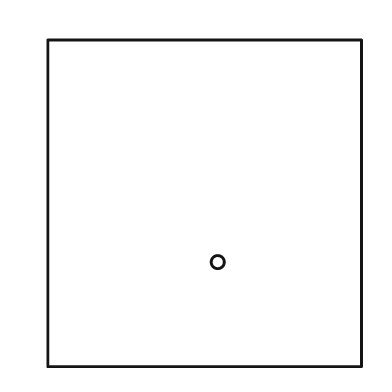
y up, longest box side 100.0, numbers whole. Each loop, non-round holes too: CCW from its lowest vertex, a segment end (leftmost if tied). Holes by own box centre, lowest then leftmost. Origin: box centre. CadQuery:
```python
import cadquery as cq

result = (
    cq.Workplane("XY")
    .moveTo(-48.0, -50.0)
    .lineTo(48.0, -50.0)
    .lineTo(48.0, 50.0)
    .lineTo(-48.0, 50.0)
    .close()
    .moveTo(4.0, -18.0)
    .circle(2.0)
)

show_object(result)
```